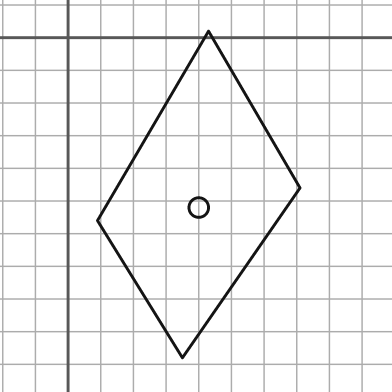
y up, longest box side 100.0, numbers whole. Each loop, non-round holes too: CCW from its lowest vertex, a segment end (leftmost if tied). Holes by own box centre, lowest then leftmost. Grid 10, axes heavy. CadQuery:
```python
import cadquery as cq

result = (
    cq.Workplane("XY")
    .moveTo(35.0, -98.0)
    .lineTo(71.0, -46.0)
    .lineTo(43.0, 2.0)
    .lineTo(9.0, -56.0)
    .close()
    .moveTo(40.0, -52.0)
    .circle(3.0)
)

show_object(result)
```